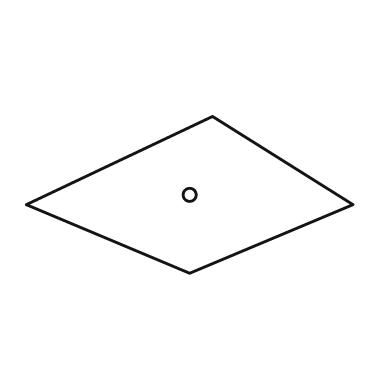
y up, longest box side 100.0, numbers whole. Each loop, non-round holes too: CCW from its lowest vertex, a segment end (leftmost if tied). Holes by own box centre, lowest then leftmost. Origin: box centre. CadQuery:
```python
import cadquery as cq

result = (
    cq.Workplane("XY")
    .moveTo(0.0, -24.0)
    .lineTo(50.0, -3.0)
    .lineTo(7.0, 24.0)
    .lineTo(-50.0, -3.0)
    .close()
    .moveTo(0.0, 0.0)
    .circle(2.0)
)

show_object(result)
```